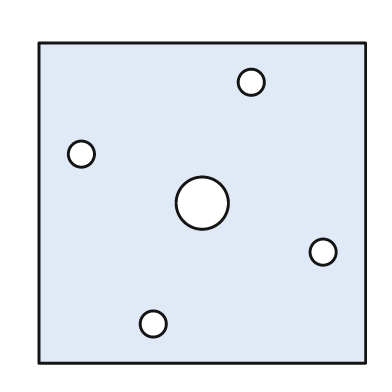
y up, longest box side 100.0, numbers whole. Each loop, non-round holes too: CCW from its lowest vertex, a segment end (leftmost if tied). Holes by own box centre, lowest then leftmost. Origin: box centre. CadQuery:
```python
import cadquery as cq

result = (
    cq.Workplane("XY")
    .moveTo(-50.0, -49.0)
    .lineTo(50.0, -49.0)
    .lineTo(50.0, 49.0)
    .lineTo(-50.0, 49.0)
    .close()
    .moveTo(-15.0, -37.0)
    .circle(4.0)
    .moveTo(37.0, -15.0)
    .circle(4.0)
    .moveTo(0.0, 0.0)
    .circle(8.0)
    .moveTo(-37.0, 15.0)
    .circle(4.0)
    .moveTo(15.0, 37.0)
    .circle(4.0)
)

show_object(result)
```